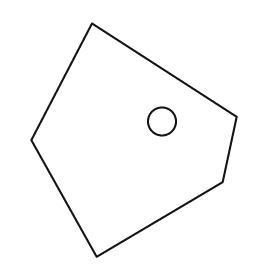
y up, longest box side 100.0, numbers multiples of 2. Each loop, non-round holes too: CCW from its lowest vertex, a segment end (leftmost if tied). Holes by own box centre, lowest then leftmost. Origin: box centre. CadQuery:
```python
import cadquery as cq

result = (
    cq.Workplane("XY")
    .moveTo(-16.0, -50.0)
    .lineTo(38.0, -18.0)
    .lineTo(44.0, 10.0)
    .lineTo(-18.0, 50.0)
    .lineTo(-44.0, 0.0)
    .close()
    .moveTo(12.0, 8.0)
    .circle(6.0)
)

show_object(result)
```